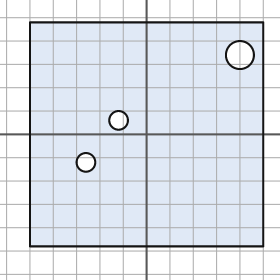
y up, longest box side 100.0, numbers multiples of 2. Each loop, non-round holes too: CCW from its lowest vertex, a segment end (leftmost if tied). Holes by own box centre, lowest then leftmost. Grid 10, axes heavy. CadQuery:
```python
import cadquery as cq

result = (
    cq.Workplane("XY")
    .moveTo(-50.0, -48.0)
    .lineTo(50.0, -48.0)
    .lineTo(50.0, 48.0)
    .lineTo(-50.0, 48.0)
    .close()
    .moveTo(-26.0, -12.0)
    .circle(4.0)
    .moveTo(-12.0, 6.0)
    .circle(4.0)
    .moveTo(40.0, 34.0)
    .circle(6.0)
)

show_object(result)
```